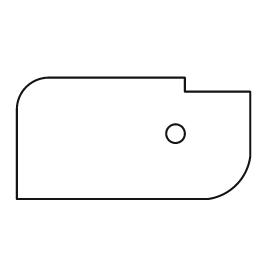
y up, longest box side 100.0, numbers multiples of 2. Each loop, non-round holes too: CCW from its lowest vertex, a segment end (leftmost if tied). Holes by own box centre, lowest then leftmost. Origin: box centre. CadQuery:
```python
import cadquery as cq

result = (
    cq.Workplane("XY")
    .moveTo(-50.0, -26.0)
    .lineTo(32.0, -26.0)
    .threePointArc((44.0, -20.0), (50.0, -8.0))
    .lineTo(50.0, 20.0)
    .lineTo(22.0, 20.0)
    .lineTo(22.0, 26.0)
    .lineTo(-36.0, 26.0)
    .threePointArc((-46.0, 22.0), (-50.0, 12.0))
    .close()
    .moveTo(18.0, 2.0)
    .circle(4.0)
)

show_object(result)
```